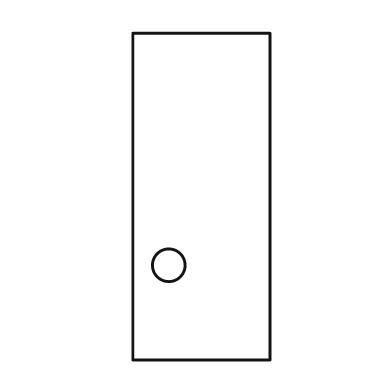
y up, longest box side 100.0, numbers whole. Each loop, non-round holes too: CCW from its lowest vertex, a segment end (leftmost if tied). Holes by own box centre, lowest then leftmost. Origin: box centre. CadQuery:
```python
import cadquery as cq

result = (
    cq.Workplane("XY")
    .moveTo(-21.0, -50.0)
    .lineTo(21.0, -50.0)
    .lineTo(21.0, 50.0)
    .lineTo(-21.0, 50.0)
    .close()
    .moveTo(-10.0, -21.0)
    .circle(5.0)
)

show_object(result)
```